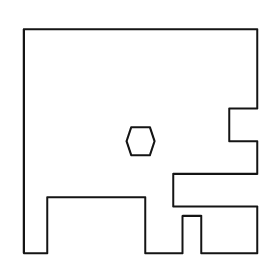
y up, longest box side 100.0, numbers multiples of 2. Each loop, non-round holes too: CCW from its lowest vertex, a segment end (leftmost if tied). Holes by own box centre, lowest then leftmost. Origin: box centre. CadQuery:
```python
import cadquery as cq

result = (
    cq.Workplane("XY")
    .moveTo(-50.0, -48.0)
    .lineTo(-40.0, -48.0)
    .lineTo(-40.0, -24.0)
    .lineTo(2.0, -24.0)
    .lineTo(2.0, -48.0)
    .lineTo(18.0, -48.0)
    .lineTo(18.0, -32.0)
    .lineTo(26.0, -32.0)
    .lineTo(26.0, -48.0)
    .lineTo(50.0, -48.0)
    .lineTo(50.0, -28.0)
    .lineTo(14.0, -28.0)
    .lineTo(14.0, -14.0)
    .lineTo(50.0, -14.0)
    .lineTo(50.0, 0.0)
    .lineTo(38.0, 0.0)
    .lineTo(38.0, 14.0)
    .lineTo(50.0, 14.0)
    .lineTo(50.0, 48.0)
    .lineTo(-50.0, 48.0)
    .close()
    .moveTo(-4.0, -6.0)
    .lineTo(4.0, -6.0)
    .lineTo(6.0, 0.0)
    .lineTo(4.0, 6.0)
    .lineTo(-4.0, 6.0)
    .lineTo(-6.0, 0.0)
    .close()
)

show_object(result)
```